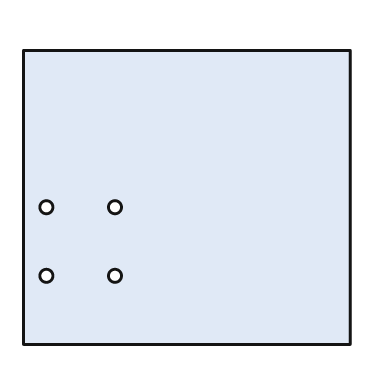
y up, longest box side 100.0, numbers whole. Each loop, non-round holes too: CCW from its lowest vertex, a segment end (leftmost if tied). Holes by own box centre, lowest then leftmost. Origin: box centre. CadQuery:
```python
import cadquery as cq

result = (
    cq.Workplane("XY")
    .moveTo(-50.0, -45.0)
    .lineTo(50.0, -45.0)
    .lineTo(50.0, 45.0)
    .lineTo(-50.0, 45.0)
    .close()
    .moveTo(-43.0, -24.0)
    .circle(2.0)
    .moveTo(-22.0, -24.0)
    .circle(2.0)
    .moveTo(-43.0, -3.0)
    .circle(2.0)
    .moveTo(-22.0, -3.0)
    .circle(2.0)
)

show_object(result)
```